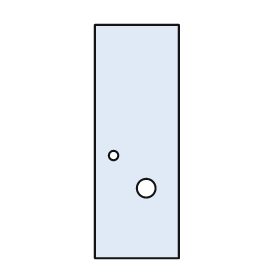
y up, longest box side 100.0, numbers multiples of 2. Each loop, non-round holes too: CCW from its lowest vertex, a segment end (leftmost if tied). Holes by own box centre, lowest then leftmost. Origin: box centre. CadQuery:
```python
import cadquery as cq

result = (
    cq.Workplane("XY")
    .moveTo(-18.0, -50.0)
    .lineTo(18.0, -50.0)
    .lineTo(18.0, 50.0)
    .lineTo(-18.0, 50.0)
    .close()
    .moveTo(4.0, -20.0)
    .circle(4.0)
    .moveTo(-10.0, -6.0)
    .circle(2.0)
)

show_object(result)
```